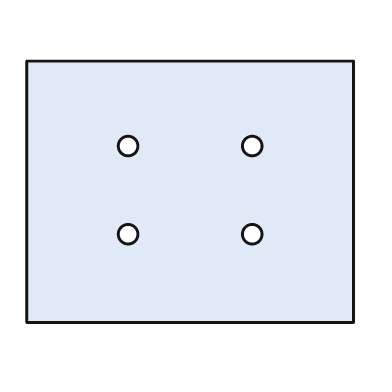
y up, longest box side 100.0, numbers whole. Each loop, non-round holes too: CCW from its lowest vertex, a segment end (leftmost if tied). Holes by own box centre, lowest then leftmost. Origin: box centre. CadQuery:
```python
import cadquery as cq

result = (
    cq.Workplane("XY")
    .moveTo(-50.0, -40.0)
    .lineTo(50.0, -40.0)
    .lineTo(50.0, 40.0)
    .lineTo(-50.0, 40.0)
    .close()
    .moveTo(-19.0, -13.0)
    .circle(3.0)
    .moveTo(19.0, -13.0)
    .circle(3.0)
    .moveTo(-19.0, 14.0)
    .circle(3.0)
    .moveTo(19.0, 14.0)
    .circle(3.0)
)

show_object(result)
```